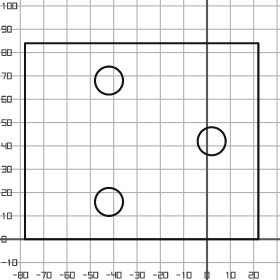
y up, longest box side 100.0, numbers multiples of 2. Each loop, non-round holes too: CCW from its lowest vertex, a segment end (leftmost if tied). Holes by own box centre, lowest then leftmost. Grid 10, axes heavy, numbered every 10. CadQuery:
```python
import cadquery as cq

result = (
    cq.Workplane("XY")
    .moveTo(-78.0, 0.0)
    .lineTo(22.0, 0.0)
    .lineTo(22.0, 84.0)
    .lineTo(-78.0, 84.0)
    .close()
    .moveTo(-42.0, 16.0)
    .circle(6.0)
    .moveTo(2.0, 42.0)
    .circle(6.0)
    .moveTo(-42.0, 68.0)
    .circle(6.0)
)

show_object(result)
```